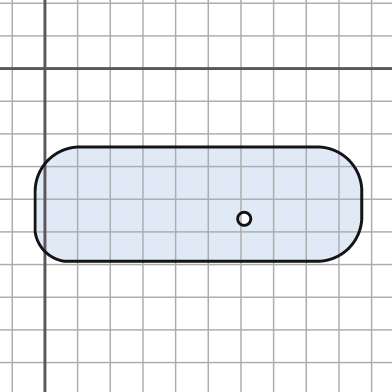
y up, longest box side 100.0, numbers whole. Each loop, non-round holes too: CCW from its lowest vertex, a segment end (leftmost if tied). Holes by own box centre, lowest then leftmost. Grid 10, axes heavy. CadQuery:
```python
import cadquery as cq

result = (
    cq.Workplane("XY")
    .moveTo(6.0, -59.0)
    .lineTo(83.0, -59.0)
    .threePointArc((93.0, -55.0), (97.0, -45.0))
    .lineTo(97.0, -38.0)
    .threePointArc((93.0, -28.0), (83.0, -24.0))
    .lineTo(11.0, -24.0)
    .threePointArc((1.0, -28.0), (-3.0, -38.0))
    .lineTo(-3.0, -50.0)
    .threePointArc((0.0, -56.0), (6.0, -59.0))
    .close()
    .moveTo(61.0, -46.0)
    .circle(2.0)
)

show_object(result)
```